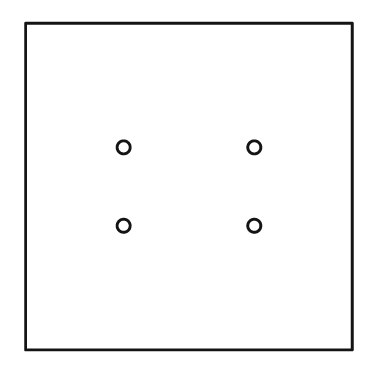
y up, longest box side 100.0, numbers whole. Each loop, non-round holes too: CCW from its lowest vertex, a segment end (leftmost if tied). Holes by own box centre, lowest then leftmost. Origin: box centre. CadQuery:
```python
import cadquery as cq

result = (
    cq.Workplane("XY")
    .moveTo(-50.0, -50.0)
    .lineTo(50.0, -50.0)
    .lineTo(50.0, 50.0)
    .lineTo(-50.0, 50.0)
    .close()
    .moveTo(-20.0, -12.0)
    .circle(2.0)
    .moveTo(20.0, -12.0)
    .circle(2.0)
    .moveTo(-20.0, 12.0)
    .circle(2.0)
    .moveTo(20.0, 12.0)
    .circle(2.0)
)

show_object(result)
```